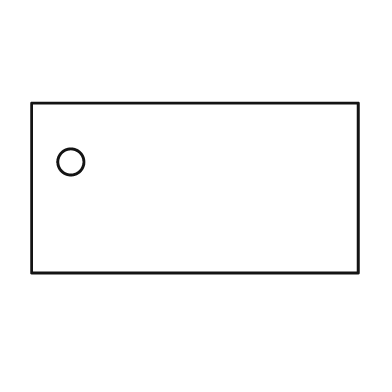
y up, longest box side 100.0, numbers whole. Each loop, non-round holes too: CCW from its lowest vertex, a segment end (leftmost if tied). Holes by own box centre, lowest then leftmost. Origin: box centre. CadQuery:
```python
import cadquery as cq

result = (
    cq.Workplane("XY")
    .moveTo(-50.0, -26.0)
    .lineTo(50.0, -26.0)
    .lineTo(50.0, 26.0)
    .lineTo(-50.0, 26.0)
    .close()
    .moveTo(-38.0, 8.0)
    .circle(4.0)
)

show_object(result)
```